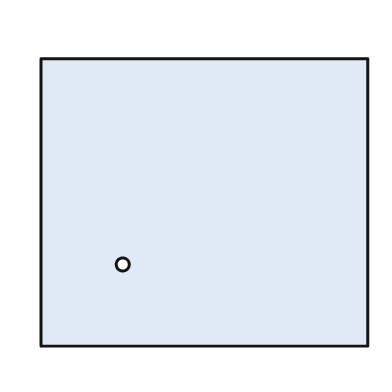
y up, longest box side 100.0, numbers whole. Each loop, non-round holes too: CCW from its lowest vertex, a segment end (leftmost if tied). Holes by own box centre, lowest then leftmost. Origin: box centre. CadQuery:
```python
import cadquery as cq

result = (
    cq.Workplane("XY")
    .moveTo(-50.0, -44.0)
    .lineTo(50.0, -44.0)
    .lineTo(50.0, 44.0)
    .lineTo(-50.0, 44.0)
    .close()
    .moveTo(-25.0, -19.0)
    .circle(2.0)
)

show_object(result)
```